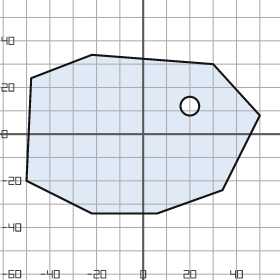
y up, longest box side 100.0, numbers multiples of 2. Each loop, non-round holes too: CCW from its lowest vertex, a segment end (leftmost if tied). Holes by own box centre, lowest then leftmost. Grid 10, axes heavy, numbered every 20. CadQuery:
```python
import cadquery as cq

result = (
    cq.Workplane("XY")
    .moveTo(-22.0, -34.0)
    .lineTo(6.0, -34.0)
    .lineTo(34.0, -24.0)
    .lineTo(50.0, 8.0)
    .lineTo(30.0, 30.0)
    .lineTo(-22.0, 34.0)
    .lineTo(-48.0, 24.0)
    .lineTo(-50.0, -20.0)
    .close()
    .moveTo(20.0, 12.0)
    .circle(4.0)
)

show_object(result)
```